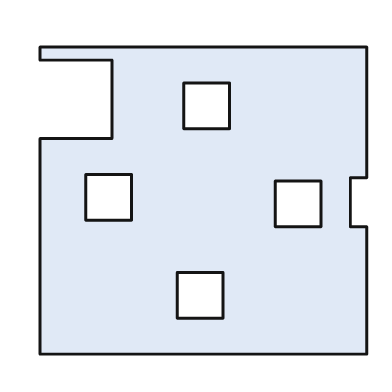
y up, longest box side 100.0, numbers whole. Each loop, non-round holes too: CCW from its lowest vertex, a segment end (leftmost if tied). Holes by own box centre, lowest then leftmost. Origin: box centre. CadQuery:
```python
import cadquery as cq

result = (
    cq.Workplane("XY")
    .moveTo(-50.0, -47.0)
    .lineTo(50.0, -47.0)
    .lineTo(50.0, -8.0)
    .lineTo(45.0, -8.0)
    .lineTo(45.0, 7.0)
    .lineTo(50.0, 7.0)
    .lineTo(50.0, 47.0)
    .lineTo(-50.0, 47.0)
    .lineTo(-50.0, 43.0)
    .lineTo(-28.0, 43.0)
    .lineTo(-28.0, 19.0)
    .lineTo(-50.0, 19.0)
    .close()
    .moveTo(-8.0, -36.0)
    .lineTo(6.0, -36.0)
    .lineTo(6.0, -22.0)
    .lineTo(-8.0, -22.0)
    .close()
    .moveTo(22.0, -8.0)
    .lineTo(36.0, -8.0)
    .lineTo(36.0, 6.0)
    .lineTo(22.0, 6.0)
    .close()
    .moveTo(-36.0, -6.0)
    .lineTo(-22.0, -6.0)
    .lineTo(-22.0, 8.0)
    .lineTo(-36.0, 8.0)
    .close()
    .moveTo(-6.0, 22.0)
    .lineTo(8.0, 22.0)
    .lineTo(8.0, 36.0)
    .lineTo(-6.0, 36.0)
    .close()
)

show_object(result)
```